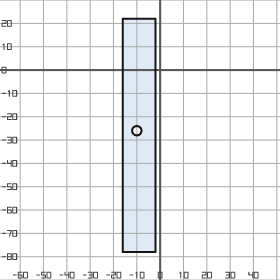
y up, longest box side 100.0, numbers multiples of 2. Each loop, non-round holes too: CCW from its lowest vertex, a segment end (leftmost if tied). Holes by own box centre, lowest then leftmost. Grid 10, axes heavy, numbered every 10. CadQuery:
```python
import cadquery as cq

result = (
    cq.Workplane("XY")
    .moveTo(-16.0, -78.0)
    .lineTo(-2.0, -78.0)
    .lineTo(-2.0, 22.0)
    .lineTo(-16.0, 22.0)
    .close()
    .moveTo(-10.0, -26.0)
    .circle(2.0)
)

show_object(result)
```